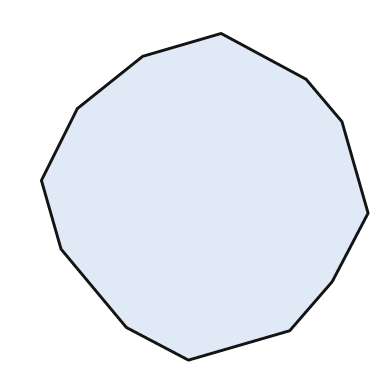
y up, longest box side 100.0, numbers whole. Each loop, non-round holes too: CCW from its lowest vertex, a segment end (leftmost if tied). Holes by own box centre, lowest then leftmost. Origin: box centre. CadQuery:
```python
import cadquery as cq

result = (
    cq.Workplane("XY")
    .moveTo(-5.0, -50.0)
    .lineTo(26.0, -41.0)
    .lineTo(39.0, -26.0)
    .lineTo(50.0, -5.0)
    .lineTo(42.0, 23.0)
    .lineTo(31.0, 36.0)
    .lineTo(5.0, 50.0)
    .lineTo(-19.0, 43.0)
    .lineTo(-39.0, 27.0)
    .lineTo(-50.0, 5.0)
    .lineTo(-44.0, -16.0)
    .lineTo(-24.0, -40.0)
    .close()
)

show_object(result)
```